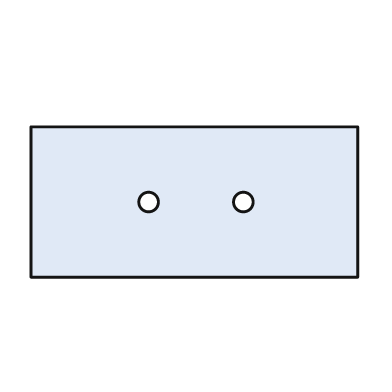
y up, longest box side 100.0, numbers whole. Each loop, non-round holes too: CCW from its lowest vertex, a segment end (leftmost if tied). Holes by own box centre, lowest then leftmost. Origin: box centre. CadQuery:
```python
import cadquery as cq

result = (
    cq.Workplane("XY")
    .moveTo(-50.0, -23.0)
    .lineTo(50.0, -23.0)
    .lineTo(50.0, 23.0)
    .lineTo(-50.0, 23.0)
    .close()
    .moveTo(-14.0, 0.0)
    .circle(3.0)
    .moveTo(15.0, 0.0)
    .circle(3.0)
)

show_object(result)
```